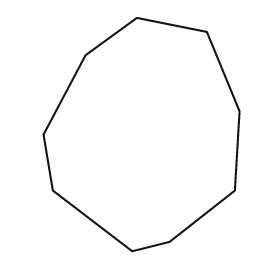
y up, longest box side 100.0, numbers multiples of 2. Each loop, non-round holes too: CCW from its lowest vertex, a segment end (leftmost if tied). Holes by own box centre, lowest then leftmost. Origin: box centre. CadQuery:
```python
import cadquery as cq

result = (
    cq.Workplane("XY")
    .moveTo(-4.0, -50.0)
    .lineTo(12.0, -46.0)
    .lineTo(40.0, -24.0)
    .lineTo(42.0, 10.0)
    .lineTo(28.0, 44.0)
    .lineTo(-2.0, 50.0)
    .lineTo(-24.0, 34.0)
    .lineTo(-42.0, 0.0)
    .lineTo(-38.0, -24.0)
    .close()
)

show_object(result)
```